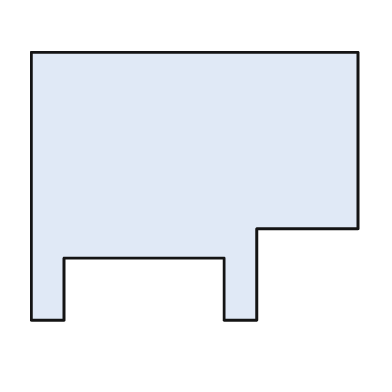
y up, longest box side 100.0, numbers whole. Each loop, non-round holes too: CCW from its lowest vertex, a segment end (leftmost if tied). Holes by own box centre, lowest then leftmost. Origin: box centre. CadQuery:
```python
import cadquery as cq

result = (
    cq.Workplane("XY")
    .moveTo(-50.0, -41.0)
    .lineTo(-40.0, -41.0)
    .lineTo(-40.0, -22.0)
    .lineTo(9.0, -22.0)
    .lineTo(9.0, -41.0)
    .lineTo(19.0, -41.0)
    .lineTo(19.0, -13.0)
    .lineTo(50.0, -13.0)
    .lineTo(50.0, 41.0)
    .lineTo(-50.0, 41.0)
    .close()
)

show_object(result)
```